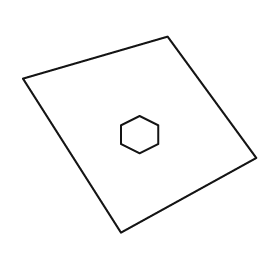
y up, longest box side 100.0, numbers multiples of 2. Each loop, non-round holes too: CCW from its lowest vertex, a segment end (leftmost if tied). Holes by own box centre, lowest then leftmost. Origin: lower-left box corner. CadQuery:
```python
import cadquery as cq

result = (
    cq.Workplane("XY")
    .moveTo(42.0, 0.0)
    .lineTo(100.0, 32.0)
    .lineTo(62.0, 84.0)
    .lineTo(0.0, 66.0)
    .close()
    .moveTo(50.0, 34.0)
    .lineTo(58.0, 38.0)
    .lineTo(58.0, 46.0)
    .lineTo(50.0, 50.0)
    .lineTo(42.0, 46.0)
    .lineTo(42.0, 38.0)
    .close()
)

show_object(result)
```